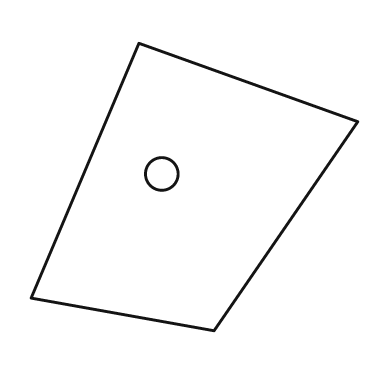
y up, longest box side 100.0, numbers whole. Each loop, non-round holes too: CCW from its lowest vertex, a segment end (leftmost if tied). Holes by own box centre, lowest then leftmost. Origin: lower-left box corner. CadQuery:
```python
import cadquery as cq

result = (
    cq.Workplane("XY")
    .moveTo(56.0, 0.0)
    .lineTo(100.0, 64.0)
    .lineTo(33.0, 88.0)
    .lineTo(0.0, 10.0)
    .close()
    .moveTo(40.0, 48.0)
    .circle(5.0)
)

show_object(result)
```